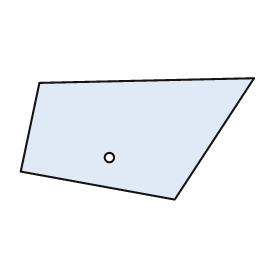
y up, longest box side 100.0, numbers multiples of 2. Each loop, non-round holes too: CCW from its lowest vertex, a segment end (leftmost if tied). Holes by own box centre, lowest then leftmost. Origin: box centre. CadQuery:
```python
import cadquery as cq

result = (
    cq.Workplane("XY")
    .moveTo(16.0, -26.0)
    .lineTo(50.0, 26.0)
    .lineTo(-42.0, 24.0)
    .lineTo(-50.0, -14.0)
    .close()
    .moveTo(-12.0, -8.0)
    .circle(2.0)
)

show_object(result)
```